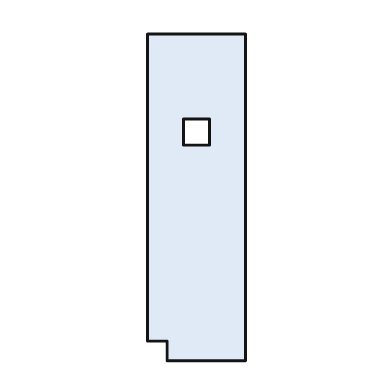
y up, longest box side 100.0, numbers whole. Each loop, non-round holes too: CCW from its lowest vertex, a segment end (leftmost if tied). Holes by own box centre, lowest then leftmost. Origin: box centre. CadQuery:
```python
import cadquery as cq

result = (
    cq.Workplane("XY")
    .moveTo(-9.0, -50.0)
    .lineTo(15.0, -50.0)
    .lineTo(15.0, 50.0)
    .lineTo(-15.0, 50.0)
    .lineTo(-15.0, -44.0)
    .lineTo(-9.0, -44.0)
    .close()
    .moveTo(-4.0, 16.0)
    .lineTo(4.0, 16.0)
    .lineTo(4.0, 24.0)
    .lineTo(-4.0, 24.0)
    .close()
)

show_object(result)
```